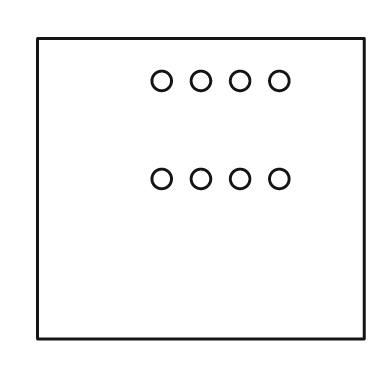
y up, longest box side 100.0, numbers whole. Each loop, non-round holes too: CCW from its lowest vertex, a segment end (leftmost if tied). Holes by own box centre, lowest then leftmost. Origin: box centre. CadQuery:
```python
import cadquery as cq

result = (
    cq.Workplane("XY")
    .moveTo(-50.0, -46.0)
    .lineTo(50.0, -46.0)
    .lineTo(50.0, 46.0)
    .lineTo(-50.0, 46.0)
    .close()
    .moveTo(-12.0, 3.0)
    .circle(3.0)
    .moveTo(0.0, 3.0)
    .circle(3.0)
    .moveTo(12.0, 3.0)
    .circle(3.0)
    .moveTo(24.0, 3.0)
    .circle(3.0)
    .moveTo(-12.0, 33.0)
    .circle(3.0)
    .moveTo(0.0, 33.0)
    .circle(3.0)
    .moveTo(12.0, 33.0)
    .circle(3.0)
    .moveTo(24.0, 33.0)
    .circle(3.0)
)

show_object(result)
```